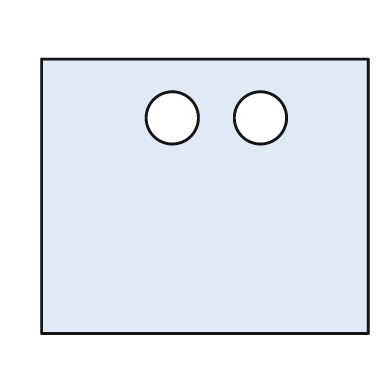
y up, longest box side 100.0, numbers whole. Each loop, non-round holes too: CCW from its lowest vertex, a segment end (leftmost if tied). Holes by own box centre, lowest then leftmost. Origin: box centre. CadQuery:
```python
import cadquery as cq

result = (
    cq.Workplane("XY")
    .moveTo(-50.0, -42.0)
    .lineTo(50.0, -42.0)
    .lineTo(50.0, 42.0)
    .lineTo(-50.0, 42.0)
    .close()
    .moveTo(-10.0, 24.0)
    .circle(8.0)
    .moveTo(17.0, 24.0)
    .circle(8.0)
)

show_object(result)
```